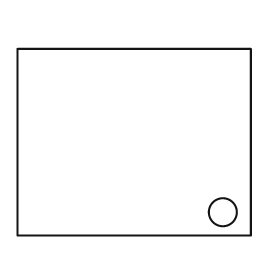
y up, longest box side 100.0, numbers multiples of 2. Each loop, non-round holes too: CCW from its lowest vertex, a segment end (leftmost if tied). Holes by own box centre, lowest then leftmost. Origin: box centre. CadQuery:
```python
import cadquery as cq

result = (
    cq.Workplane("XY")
    .moveTo(-50.0, -40.0)
    .lineTo(50.0, -40.0)
    .lineTo(50.0, 40.0)
    .lineTo(-50.0, 40.0)
    .close()
    .moveTo(38.0, -30.0)
    .circle(6.0)
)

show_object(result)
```